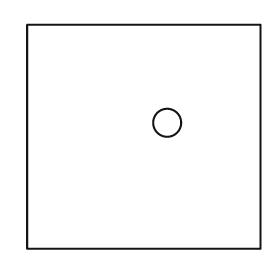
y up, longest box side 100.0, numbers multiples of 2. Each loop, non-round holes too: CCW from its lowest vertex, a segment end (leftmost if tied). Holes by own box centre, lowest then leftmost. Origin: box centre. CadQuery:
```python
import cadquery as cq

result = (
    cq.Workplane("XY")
    .moveTo(-50.0, -48.0)
    .lineTo(50.0, -48.0)
    .lineTo(50.0, 48.0)
    .lineTo(-50.0, 48.0)
    .close()
    .moveTo(10.0, 6.0)
    .circle(6.0)
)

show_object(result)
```